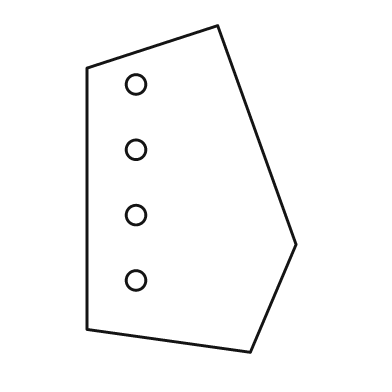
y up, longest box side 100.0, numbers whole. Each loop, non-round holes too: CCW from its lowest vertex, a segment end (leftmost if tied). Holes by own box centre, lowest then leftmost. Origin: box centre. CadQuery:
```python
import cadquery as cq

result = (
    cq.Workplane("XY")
    .moveTo(18.0, -50.0)
    .lineTo(32.0, -17.0)
    .lineTo(8.0, 50.0)
    .lineTo(-32.0, 37.0)
    .lineTo(-32.0, -43.0)
    .close()
    .moveTo(-17.0, -28.0)
    .circle(3.0)
    .moveTo(-17.0, -8.0)
    .circle(3.0)
    .moveTo(-17.0, 12.0)
    .circle(3.0)
    .moveTo(-17.0, 32.0)
    .circle(3.0)
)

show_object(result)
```